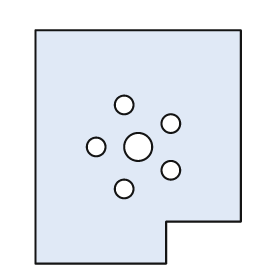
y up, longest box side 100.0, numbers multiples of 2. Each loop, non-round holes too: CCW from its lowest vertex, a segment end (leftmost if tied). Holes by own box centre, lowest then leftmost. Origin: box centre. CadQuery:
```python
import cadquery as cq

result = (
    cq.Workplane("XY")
    .moveTo(-44.0, -50.0)
    .lineTo(12.0, -50.0)
    .lineTo(12.0, -32.0)
    .lineTo(44.0, -32.0)
    .lineTo(44.0, 50.0)
    .lineTo(-44.0, 50.0)
    .close()
    .moveTo(-6.0, -18.0)
    .circle(4.0)
    .moveTo(14.0, -10.0)
    .circle(4.0)
    .moveTo(-18.0, 0.0)
    .circle(4.0)
    .moveTo(0.0, 0.0)
    .circle(6.0)
    .moveTo(14.0, 10.0)
    .circle(4.0)
    .moveTo(-6.0, 18.0)
    .circle(4.0)
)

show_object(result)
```